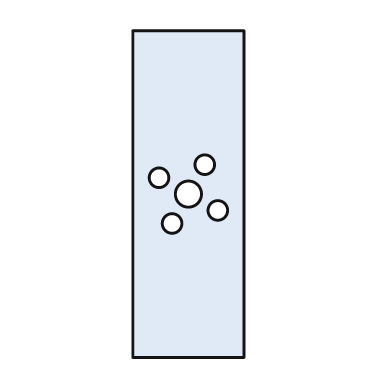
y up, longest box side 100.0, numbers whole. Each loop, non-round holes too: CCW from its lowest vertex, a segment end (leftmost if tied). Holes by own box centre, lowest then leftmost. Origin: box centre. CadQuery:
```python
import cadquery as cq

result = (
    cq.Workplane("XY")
    .moveTo(-17.0, -50.0)
    .lineTo(17.0, -50.0)
    .lineTo(17.0, 50.0)
    .lineTo(-17.0, 50.0)
    .close()
    .moveTo(-5.0, -9.0)
    .circle(3.0)
    .moveTo(9.0, -5.0)
    .circle(3.0)
    .moveTo(0.0, 0.0)
    .circle(4.0)
    .moveTo(-9.0, 5.0)
    .circle(3.0)
    .moveTo(5.0, 9.0)
    .circle(3.0)
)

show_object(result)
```